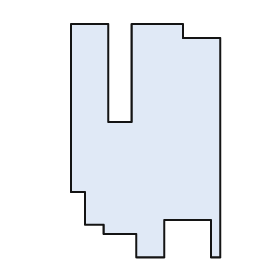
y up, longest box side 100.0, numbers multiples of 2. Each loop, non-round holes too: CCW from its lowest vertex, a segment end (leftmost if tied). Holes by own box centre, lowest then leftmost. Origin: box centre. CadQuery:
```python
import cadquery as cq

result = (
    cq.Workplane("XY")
    .moveTo(-4.0, -50.0)
    .lineTo(8.0, -50.0)
    .lineTo(8.0, -34.0)
    .lineTo(28.0, -34.0)
    .lineTo(28.0, -50.0)
    .lineTo(32.0, -50.0)
    .lineTo(32.0, 44.0)
    .lineTo(16.0, 44.0)
    .lineTo(16.0, 50.0)
    .lineTo(-6.0, 50.0)
    .lineTo(-6.0, 8.0)
    .lineTo(-16.0, 8.0)
    .lineTo(-16.0, 50.0)
    .lineTo(-32.0, 50.0)
    .lineTo(-32.0, -22.0)
    .lineTo(-26.0, -22.0)
    .lineTo(-26.0, -36.0)
    .lineTo(-18.0, -36.0)
    .lineTo(-18.0, -40.0)
    .lineTo(-4.0, -40.0)
    .close()
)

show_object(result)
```